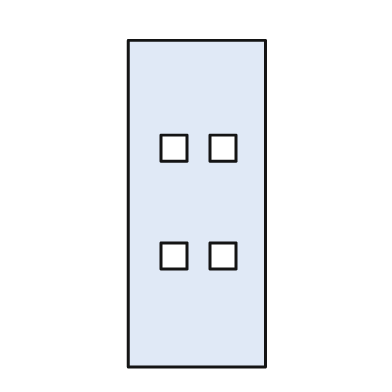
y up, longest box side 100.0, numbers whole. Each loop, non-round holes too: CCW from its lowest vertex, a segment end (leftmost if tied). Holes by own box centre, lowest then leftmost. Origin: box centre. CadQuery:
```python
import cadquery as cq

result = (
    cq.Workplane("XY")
    .moveTo(-21.0, -50.0)
    .lineTo(21.0, -50.0)
    .lineTo(21.0, 50.0)
    .lineTo(-21.0, 50.0)
    .close()
    .moveTo(-11.0, -20.0)
    .lineTo(-3.0, -20.0)
    .lineTo(-3.0, -12.0)
    .lineTo(-11.0, -12.0)
    .close()
    .moveTo(4.0, -20.0)
    .lineTo(12.0, -20.0)
    .lineTo(12.0, -12.0)
    .lineTo(4.0, -12.0)
    .close()
    .moveTo(-11.0, 13.0)
    .lineTo(-3.0, 13.0)
    .lineTo(-3.0, 21.0)
    .lineTo(-11.0, 21.0)
    .close()
    .moveTo(4.0, 13.0)
    .lineTo(12.0, 13.0)
    .lineTo(12.0, 21.0)
    .lineTo(4.0, 21.0)
    .close()
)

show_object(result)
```